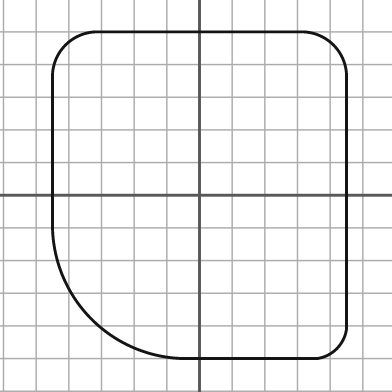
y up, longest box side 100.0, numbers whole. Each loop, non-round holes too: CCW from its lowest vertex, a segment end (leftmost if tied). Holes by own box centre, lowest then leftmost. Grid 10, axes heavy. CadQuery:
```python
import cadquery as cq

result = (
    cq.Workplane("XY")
    .moveTo(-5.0, -50.0)
    .lineTo(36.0, -50.0)
    .threePointArc((42.0, -47.0), (45.0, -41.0))
    .lineTo(45.0, 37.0)
    .threePointArc((41.0, 46.0), (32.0, 50.0))
    .lineTo(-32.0, 50.0)
    .threePointArc((-41.0, 46.0), (-45.0, 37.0))
    .lineTo(-45.0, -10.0)
    .threePointArc((-33.0, -38.0), (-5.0, -50.0))
    .close()
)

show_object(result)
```